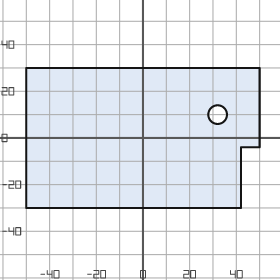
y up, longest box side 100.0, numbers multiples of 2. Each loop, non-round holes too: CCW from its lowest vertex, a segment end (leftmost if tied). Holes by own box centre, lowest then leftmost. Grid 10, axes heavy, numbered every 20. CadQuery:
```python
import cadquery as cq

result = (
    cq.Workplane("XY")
    .moveTo(-50.0, -30.0)
    .lineTo(42.0, -30.0)
    .lineTo(42.0, -4.0)
    .lineTo(50.0, -4.0)
    .lineTo(50.0, 30.0)
    .lineTo(-50.0, 30.0)
    .close()
    .moveTo(32.0, 10.0)
    .circle(4.0)
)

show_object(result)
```